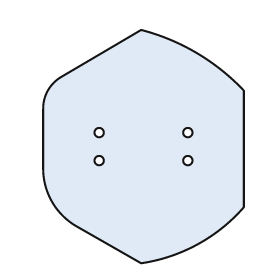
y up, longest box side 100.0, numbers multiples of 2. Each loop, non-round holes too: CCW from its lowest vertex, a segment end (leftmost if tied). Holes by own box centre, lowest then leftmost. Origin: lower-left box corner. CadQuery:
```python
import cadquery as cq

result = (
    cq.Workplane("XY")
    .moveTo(42.0, 0.0)
    .threePointArc((66.0, 8.0), (86.0, 24.0))
    .lineTo(86.0, 74.0)
    .threePointArc((66.0, 90.0), (42.0, 100.0))
    .lineTo(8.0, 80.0)
    .threePointArc((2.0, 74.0), (0.0, 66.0))
    .lineTo(0.0, 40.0)
    .threePointArc((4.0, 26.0), (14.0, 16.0))
    .close()
    .moveTo(24.0, 44.0)
    .circle(2.0)
    .moveTo(62.0, 44.0)
    .circle(2.0)
    .moveTo(24.0, 56.0)
    .circle(2.0)
    .moveTo(62.0, 56.0)
    .circle(2.0)
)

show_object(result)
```